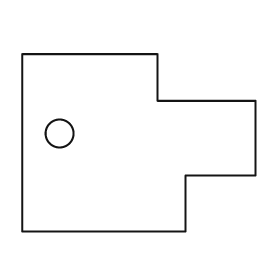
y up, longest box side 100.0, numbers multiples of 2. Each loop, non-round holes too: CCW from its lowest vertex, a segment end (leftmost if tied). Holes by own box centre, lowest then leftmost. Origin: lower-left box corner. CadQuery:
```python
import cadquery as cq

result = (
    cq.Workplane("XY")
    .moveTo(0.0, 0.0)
    .lineTo(70.0, 0.0)
    .lineTo(70.0, 24.0)
    .lineTo(100.0, 24.0)
    .lineTo(100.0, 56.0)
    .lineTo(58.0, 56.0)
    .lineTo(58.0, 76.0)
    .lineTo(0.0, 76.0)
    .close()
    .moveTo(16.0, 42.0)
    .circle(6.0)
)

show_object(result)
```